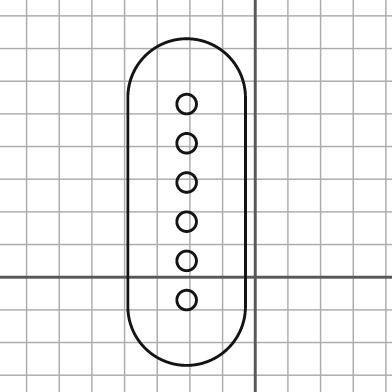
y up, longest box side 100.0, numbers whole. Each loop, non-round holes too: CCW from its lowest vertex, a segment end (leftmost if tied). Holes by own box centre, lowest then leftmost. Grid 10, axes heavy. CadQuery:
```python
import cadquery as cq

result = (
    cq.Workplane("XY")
    .moveTo(-39.0, -9.0)
    .threePointArc((-21.0, -27.0), (-3.0, -9.0))
    .lineTo(-3.0, 55.0)
    .threePointArc((-21.0, 73.0), (-39.0, 55.0))
    .close()
    .moveTo(-21.0, -7.0)
    .circle(3.0)
    .moveTo(-21.0, 5.0)
    .circle(3.0)
    .moveTo(-21.0, 17.0)
    .circle(3.0)
    .moveTo(-21.0, 29.0)
    .circle(3.0)
    .moveTo(-21.0, 41.0)
    .circle(3.0)
    .moveTo(-21.0, 53.0)
    .circle(3.0)
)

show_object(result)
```